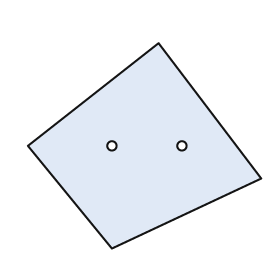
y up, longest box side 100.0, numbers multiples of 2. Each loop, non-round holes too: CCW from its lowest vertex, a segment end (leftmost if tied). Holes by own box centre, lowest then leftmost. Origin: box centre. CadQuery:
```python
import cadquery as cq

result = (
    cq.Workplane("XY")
    .moveTo(-14.0, -44.0)
    .lineTo(50.0, -14.0)
    .lineTo(6.0, 44.0)
    .lineTo(-50.0, 0.0)
    .close()
    .moveTo(-14.0, 0.0)
    .circle(2.0)
    .moveTo(16.0, 0.0)
    .circle(2.0)
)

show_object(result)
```